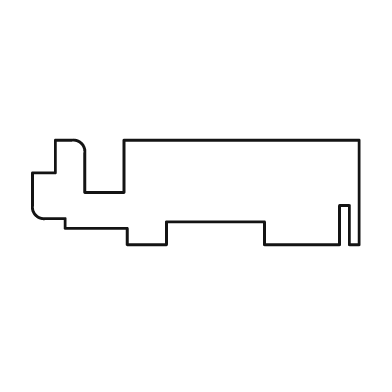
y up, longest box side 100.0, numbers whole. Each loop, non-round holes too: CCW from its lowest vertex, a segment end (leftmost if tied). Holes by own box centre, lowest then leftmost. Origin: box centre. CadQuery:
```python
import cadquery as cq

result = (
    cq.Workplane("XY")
    .moveTo(-21.0, -16.0)
    .lineTo(-9.0, -16.0)
    .lineTo(-9.0, -9.0)
    .lineTo(21.0, -9.0)
    .lineTo(21.0, -16.0)
    .lineTo(44.0, -16.0)
    .lineTo(44.0, -4.0)
    .lineTo(47.0, -4.0)
    .lineTo(47.0, -16.0)
    .lineTo(50.0, -16.0)
    .lineTo(50.0, 16.0)
    .lineTo(-22.0, 16.0)
    .lineTo(-22.0, 0.0)
    .lineTo(-34.0, 0.0)
    .lineTo(-34.0, 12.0)
    .threePointArc((-35.0, 15.0), (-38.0, 16.0))
    .lineTo(-43.0, 16.0)
    .lineTo(-43.0, 6.0)
    .lineTo(-50.0, 6.0)
    .lineTo(-50.0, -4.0)
    .threePointArc((-49.0, -7.0), (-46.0, -8.0))
    .lineTo(-40.0, -8.0)
    .lineTo(-40.0, -11.0)
    .lineTo(-21.0, -11.0)
    .close()
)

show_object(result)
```